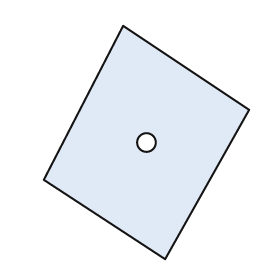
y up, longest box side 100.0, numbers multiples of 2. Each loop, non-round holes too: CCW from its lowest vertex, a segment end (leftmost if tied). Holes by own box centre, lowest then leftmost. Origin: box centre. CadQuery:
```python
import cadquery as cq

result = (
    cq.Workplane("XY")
    .moveTo(8.0, -50.0)
    .lineTo(44.0, 14.0)
    .lineTo(-10.0, 50.0)
    .lineTo(-44.0, -16.0)
    .close()
    .moveTo(0.0, 0.0)
    .circle(4.0)
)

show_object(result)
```